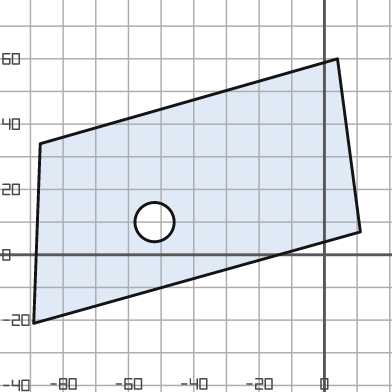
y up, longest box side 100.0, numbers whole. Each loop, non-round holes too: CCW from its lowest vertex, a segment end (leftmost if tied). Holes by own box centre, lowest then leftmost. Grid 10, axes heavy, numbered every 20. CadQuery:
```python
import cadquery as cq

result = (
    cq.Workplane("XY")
    .moveTo(-89.0, -21.0)
    .lineTo(11.0, 7.0)
    .lineTo(4.0, 60.0)
    .lineTo(-87.0, 34.0)
    .close()
    .moveTo(-52.0, 10.0)
    .circle(6.0)
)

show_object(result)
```